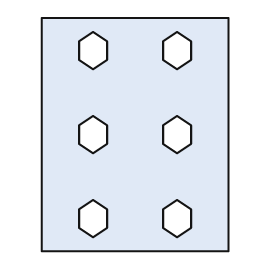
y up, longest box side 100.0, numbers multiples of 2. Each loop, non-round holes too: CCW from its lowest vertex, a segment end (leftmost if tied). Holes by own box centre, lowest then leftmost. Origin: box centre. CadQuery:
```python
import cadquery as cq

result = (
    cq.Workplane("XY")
    .moveTo(-40.0, -50.0)
    .lineTo(40.0, -50.0)
    .lineTo(40.0, 50.0)
    .lineTo(-40.0, 50.0)
    .close()
    .moveTo(-18.0, -44.0)
    .lineTo(-12.0, -40.0)
    .lineTo(-12.0, -32.0)
    .lineTo(-18.0, -28.0)
    .lineTo(-24.0, -32.0)
    .lineTo(-24.0, -40.0)
    .close()
    .moveTo(18.0, -44.0)
    .lineTo(24.0, -40.0)
    .lineTo(24.0, -32.0)
    .lineTo(18.0, -28.0)
    .lineTo(12.0, -32.0)
    .lineTo(12.0, -40.0)
    .close()
    .moveTo(-18.0, -8.0)
    .lineTo(-12.0, -4.0)
    .lineTo(-12.0, 4.0)
    .lineTo(-18.0, 8.0)
    .lineTo(-24.0, 4.0)
    .lineTo(-24.0, -4.0)
    .close()
    .moveTo(18.0, -8.0)
    .lineTo(24.0, -4.0)
    .lineTo(24.0, 4.0)
    .lineTo(18.0, 8.0)
    .lineTo(12.0, 4.0)
    .lineTo(12.0, -4.0)
    .close()
    .moveTo(-18.0, 28.0)
    .lineTo(-12.0, 32.0)
    .lineTo(-12.0, 40.0)
    .lineTo(-18.0, 44.0)
    .lineTo(-24.0, 40.0)
    .lineTo(-24.0, 32.0)
    .close()
    .moveTo(18.0, 28.0)
    .lineTo(24.0, 32.0)
    .lineTo(24.0, 40.0)
    .lineTo(18.0, 44.0)
    .lineTo(12.0, 40.0)
    .lineTo(12.0, 32.0)
    .close()
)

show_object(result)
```